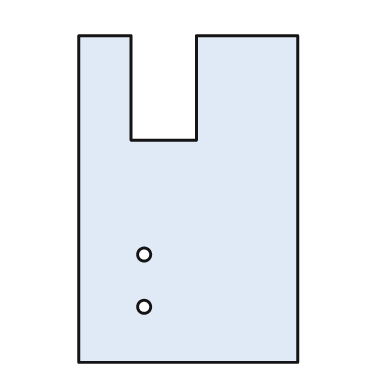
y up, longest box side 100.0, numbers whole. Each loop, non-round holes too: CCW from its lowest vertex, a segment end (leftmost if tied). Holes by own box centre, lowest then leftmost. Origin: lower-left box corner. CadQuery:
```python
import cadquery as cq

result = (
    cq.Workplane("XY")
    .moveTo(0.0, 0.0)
    .lineTo(67.0, 0.0)
    .lineTo(67.0, 100.0)
    .lineTo(36.0, 100.0)
    .lineTo(36.0, 68.0)
    .lineTo(16.0, 68.0)
    .lineTo(16.0, 100.0)
    .lineTo(0.0, 100.0)
    .close()
    .moveTo(20.0, 17.0)
    .circle(2.0)
    .moveTo(20.0, 33.0)
    .circle(2.0)
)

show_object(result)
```